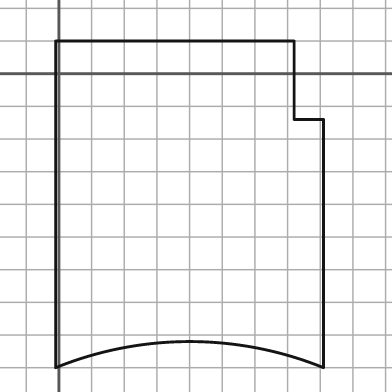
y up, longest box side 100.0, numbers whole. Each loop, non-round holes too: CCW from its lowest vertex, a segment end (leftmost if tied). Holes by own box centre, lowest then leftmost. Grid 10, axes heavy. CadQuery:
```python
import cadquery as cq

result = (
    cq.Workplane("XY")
    .moveTo(-1.0, -90.0)
    .threePointArc((40.0, -82.0), (81.0, -90.0))
    .lineTo(81.0, -14.0)
    .lineTo(72.0, -14.0)
    .lineTo(72.0, 10.0)
    .lineTo(-1.0, 10.0)
    .close()
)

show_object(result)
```